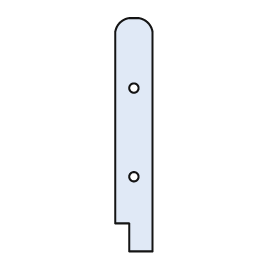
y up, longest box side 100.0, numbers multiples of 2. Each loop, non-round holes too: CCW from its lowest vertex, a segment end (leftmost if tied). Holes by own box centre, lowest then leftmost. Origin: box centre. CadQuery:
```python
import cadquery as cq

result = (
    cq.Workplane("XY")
    .moveTo(-2.0, -50.0)
    .lineTo(8.0, -50.0)
    .lineTo(8.0, 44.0)
    .threePointArc((6.0, 48.0), (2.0, 50.0))
    .lineTo(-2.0, 50.0)
    .threePointArc((-6.0, 48.0), (-8.0, 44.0))
    .lineTo(-8.0, -38.0)
    .lineTo(-2.0, -38.0)
    .close()
    .moveTo(0.0, -18.0)
    .circle(2.0)
    .moveTo(0.0, 20.0)
    .circle(2.0)
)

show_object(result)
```